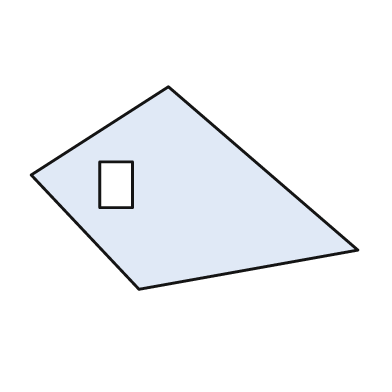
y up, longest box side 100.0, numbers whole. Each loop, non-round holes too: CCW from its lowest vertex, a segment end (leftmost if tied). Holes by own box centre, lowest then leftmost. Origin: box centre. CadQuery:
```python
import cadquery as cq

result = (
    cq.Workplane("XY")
    .moveTo(-17.0, -31.0)
    .lineTo(50.0, -19.0)
    .lineTo(-8.0, 31.0)
    .lineTo(-50.0, 4.0)
    .close()
    .moveTo(-29.0, -6.0)
    .lineTo(-19.0, -6.0)
    .lineTo(-19.0, 8.0)
    .lineTo(-29.0, 8.0)
    .close()
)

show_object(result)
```